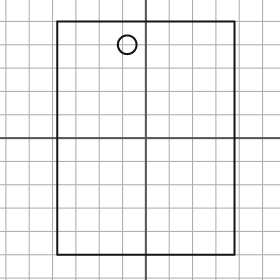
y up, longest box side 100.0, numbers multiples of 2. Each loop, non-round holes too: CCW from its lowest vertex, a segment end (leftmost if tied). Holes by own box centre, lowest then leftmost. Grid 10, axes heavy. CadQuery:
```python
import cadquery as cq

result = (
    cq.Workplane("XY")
    .moveTo(-38.0, -50.0)
    .lineTo(38.0, -50.0)
    .lineTo(38.0, 50.0)
    .lineTo(-38.0, 50.0)
    .close()
    .moveTo(-8.0, 40.0)
    .circle(4.0)
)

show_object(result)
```